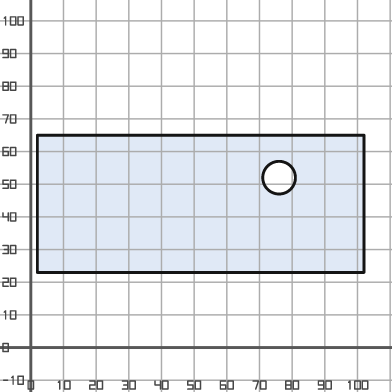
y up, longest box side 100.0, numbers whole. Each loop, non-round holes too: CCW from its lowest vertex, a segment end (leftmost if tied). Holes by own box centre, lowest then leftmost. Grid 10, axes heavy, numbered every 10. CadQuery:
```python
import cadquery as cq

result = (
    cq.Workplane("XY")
    .moveTo(2.0, 23.0)
    .lineTo(102.0, 23.0)
    .lineTo(102.0, 65.0)
    .lineTo(2.0, 65.0)
    .close()
    .moveTo(76.0, 52.0)
    .circle(5.0)
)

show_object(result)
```